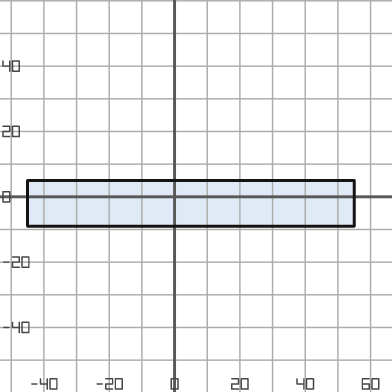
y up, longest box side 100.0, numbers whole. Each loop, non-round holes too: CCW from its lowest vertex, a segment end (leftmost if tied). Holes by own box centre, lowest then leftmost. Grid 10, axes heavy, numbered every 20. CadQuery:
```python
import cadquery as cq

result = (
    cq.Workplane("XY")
    .moveTo(-45.0, -9.0)
    .lineTo(55.0, -9.0)
    .lineTo(55.0, 5.0)
    .lineTo(-45.0, 5.0)
    .close()
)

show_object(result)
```